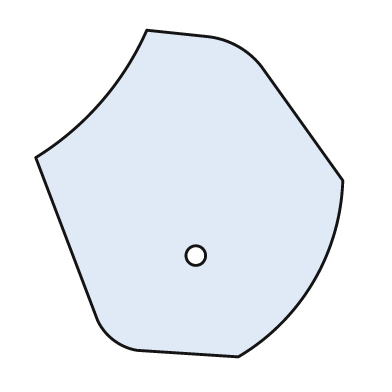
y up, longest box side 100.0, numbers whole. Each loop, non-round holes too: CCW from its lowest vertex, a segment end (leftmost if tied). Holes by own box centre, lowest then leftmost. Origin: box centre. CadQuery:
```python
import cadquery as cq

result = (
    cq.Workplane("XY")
    .moveTo(15.0, -50.0)
    .threePointArc((38.0, -27.0), (47.0, 4.0))
    .lineTo(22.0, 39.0)
    .threePointArc((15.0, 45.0), (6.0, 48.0))
    .lineTo(-13.0, 50.0)
    .threePointArc((-27.0, 28.0), (-47.0, 11.0))
    .lineTo(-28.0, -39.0)
    .threePointArc((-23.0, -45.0), (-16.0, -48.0))
    .close()
    .moveTo(2.0, -19.0)
    .circle(3.0)
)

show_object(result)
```